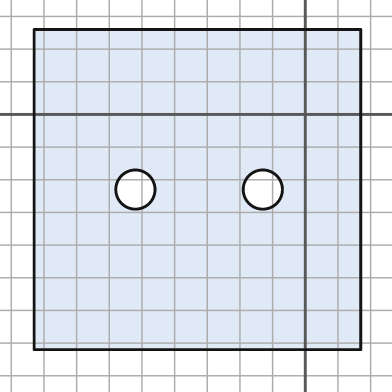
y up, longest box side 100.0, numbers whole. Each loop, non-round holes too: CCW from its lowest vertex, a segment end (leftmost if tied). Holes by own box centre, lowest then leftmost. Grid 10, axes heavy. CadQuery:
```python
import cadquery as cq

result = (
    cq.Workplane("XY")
    .moveTo(-83.0, -72.0)
    .lineTo(17.0, -72.0)
    .lineTo(17.0, 26.0)
    .lineTo(-83.0, 26.0)
    .close()
    .moveTo(-52.0, -23.0)
    .circle(6.0)
    .moveTo(-13.0, -23.0)
    .circle(6.0)
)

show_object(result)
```